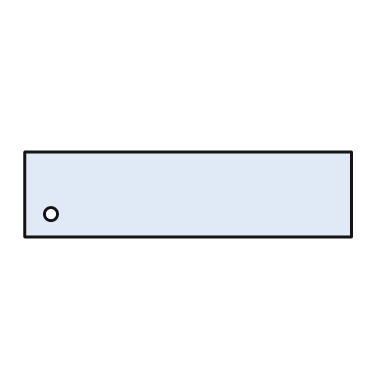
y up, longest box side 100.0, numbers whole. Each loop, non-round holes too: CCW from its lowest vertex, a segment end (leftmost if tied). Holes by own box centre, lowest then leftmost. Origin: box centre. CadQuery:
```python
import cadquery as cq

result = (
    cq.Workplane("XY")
    .moveTo(-50.0, -13.0)
    .lineTo(50.0, -13.0)
    .lineTo(50.0, 13.0)
    .lineTo(-50.0, 13.0)
    .close()
    .moveTo(-42.0, -6.0)
    .circle(2.0)
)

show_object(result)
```